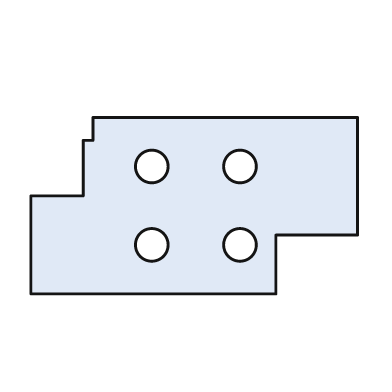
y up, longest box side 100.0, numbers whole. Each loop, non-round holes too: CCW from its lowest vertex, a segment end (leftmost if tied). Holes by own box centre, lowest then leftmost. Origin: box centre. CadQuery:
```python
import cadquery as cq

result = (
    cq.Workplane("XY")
    .moveTo(-50.0, -27.0)
    .lineTo(25.0, -27.0)
    .lineTo(25.0, -9.0)
    .lineTo(50.0, -9.0)
    .lineTo(50.0, 27.0)
    .lineTo(-31.0, 27.0)
    .lineTo(-31.0, 20.0)
    .lineTo(-34.0, 20.0)
    .lineTo(-34.0, 3.0)
    .lineTo(-50.0, 3.0)
    .close()
    .moveTo(-13.0, -12.0)
    .circle(5.0)
    .moveTo(14.0, -12.0)
    .circle(5.0)
    .moveTo(-13.0, 12.0)
    .circle(5.0)
    .moveTo(14.0, 12.0)
    .circle(5.0)
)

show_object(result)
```